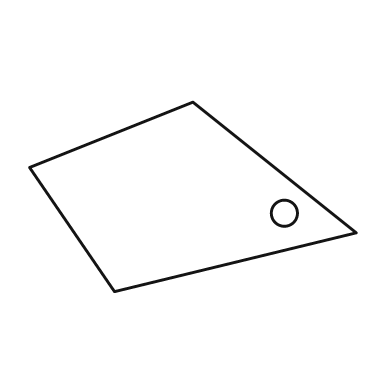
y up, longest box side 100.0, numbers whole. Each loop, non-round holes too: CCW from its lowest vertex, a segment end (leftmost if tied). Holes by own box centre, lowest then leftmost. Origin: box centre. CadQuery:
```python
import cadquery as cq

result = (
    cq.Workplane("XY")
    .moveTo(-24.0, -29.0)
    .lineTo(50.0, -11.0)
    .lineTo(0.0, 29.0)
    .lineTo(-50.0, 9.0)
    .close()
    .moveTo(28.0, -5.0)
    .circle(4.0)
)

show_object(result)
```